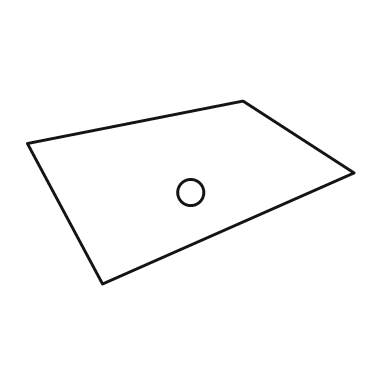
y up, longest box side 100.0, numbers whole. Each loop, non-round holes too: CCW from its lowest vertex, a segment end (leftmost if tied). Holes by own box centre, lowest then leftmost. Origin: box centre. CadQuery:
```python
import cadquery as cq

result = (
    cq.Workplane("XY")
    .moveTo(-27.0, -28.0)
    .lineTo(50.0, 6.0)
    .lineTo(16.0, 28.0)
    .lineTo(-50.0, 15.0)
    .close()
    .moveTo(0.0, 0.0)
    .circle(4.0)
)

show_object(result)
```